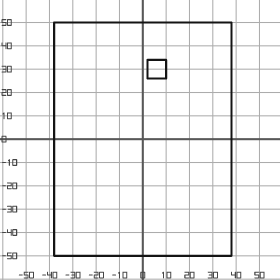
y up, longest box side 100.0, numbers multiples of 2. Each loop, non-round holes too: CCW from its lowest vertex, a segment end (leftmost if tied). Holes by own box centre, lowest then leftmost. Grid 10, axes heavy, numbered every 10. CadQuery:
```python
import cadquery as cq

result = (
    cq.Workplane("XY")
    .moveTo(-38.0, -50.0)
    .lineTo(38.0, -50.0)
    .lineTo(38.0, 50.0)
    .lineTo(-38.0, 50.0)
    .close()
    .moveTo(2.0, 26.0)
    .lineTo(10.0, 26.0)
    .lineTo(10.0, 34.0)
    .lineTo(2.0, 34.0)
    .close()
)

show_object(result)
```